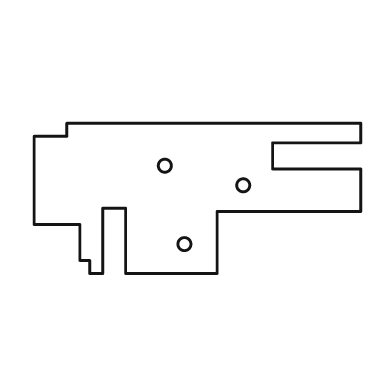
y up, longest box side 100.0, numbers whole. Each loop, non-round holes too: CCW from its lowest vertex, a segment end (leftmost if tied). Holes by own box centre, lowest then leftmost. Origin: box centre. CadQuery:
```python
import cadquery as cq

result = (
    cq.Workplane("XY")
    .moveTo(-33.0, -23.0)
    .lineTo(-29.0, -23.0)
    .lineTo(-29.0, -3.0)
    .lineTo(-22.0, -3.0)
    .lineTo(-22.0, -23.0)
    .lineTo(6.0, -23.0)
    .lineTo(6.0, -4.0)
    .lineTo(50.0, -4.0)
    .lineTo(50.0, 9.0)
    .lineTo(23.0, 9.0)
    .lineTo(23.0, 17.0)
    .lineTo(50.0, 17.0)
    .lineTo(50.0, 23.0)
    .lineTo(-40.0, 23.0)
    .lineTo(-40.0, 19.0)
    .lineTo(-50.0, 19.0)
    .lineTo(-50.0, -8.0)
    .lineTo(-36.0, -8.0)
    .lineTo(-36.0, -19.0)
    .lineTo(-33.0, -19.0)
    .close()
    .moveTo(-4.0, -14.0)
    .circle(2.0)
    .moveTo(14.0, 4.0)
    .circle(2.0)
    .moveTo(-10.0, 10.0)
    .circle(2.0)
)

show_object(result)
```